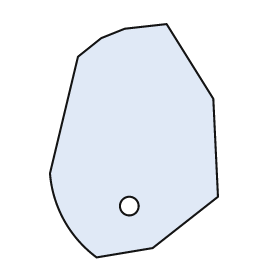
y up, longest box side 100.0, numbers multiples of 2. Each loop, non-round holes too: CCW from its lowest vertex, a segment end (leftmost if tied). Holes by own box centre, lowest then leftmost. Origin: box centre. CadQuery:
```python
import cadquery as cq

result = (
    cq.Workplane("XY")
    .moveTo(-16.0, -50.0)
    .lineTo(8.0, -46.0)
    .lineTo(36.0, -24.0)
    .lineTo(34.0, 18.0)
    .lineTo(14.0, 50.0)
    .lineTo(-4.0, 48.0)
    .lineTo(-14.0, 44.0)
    .lineTo(-24.0, 36.0)
    .lineTo(-36.0, -14.0)
    .threePointArc((-30.0, -34.0), (-16.0, -50.0))
    .close()
    .moveTo(-2.0, -28.0)
    .circle(4.0)
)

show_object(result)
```